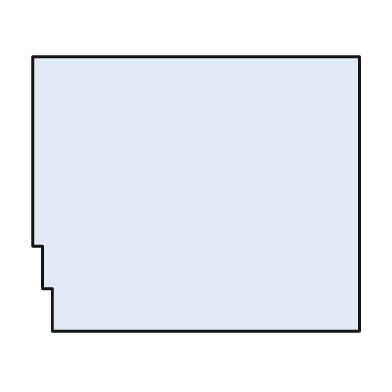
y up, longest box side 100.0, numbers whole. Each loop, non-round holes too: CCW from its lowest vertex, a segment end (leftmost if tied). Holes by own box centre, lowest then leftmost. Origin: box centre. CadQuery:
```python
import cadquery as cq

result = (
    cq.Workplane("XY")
    .moveTo(-44.0, -42.0)
    .lineTo(50.0, -42.0)
    .lineTo(50.0, 42.0)
    .lineTo(-50.0, 42.0)
    .lineTo(-50.0, -16.0)
    .lineTo(-47.0, -16.0)
    .lineTo(-47.0, -29.0)
    .lineTo(-44.0, -29.0)
    .close()
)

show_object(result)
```